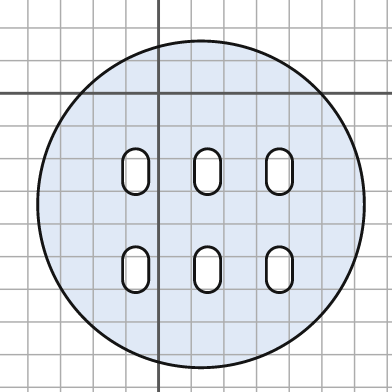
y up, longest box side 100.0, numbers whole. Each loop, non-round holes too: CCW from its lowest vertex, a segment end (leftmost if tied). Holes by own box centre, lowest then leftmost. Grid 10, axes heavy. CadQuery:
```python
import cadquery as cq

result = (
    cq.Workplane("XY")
    .moveTo(13.0, -34.0)
    .circle(50.0)
    .moveTo(-11.0, -57.0)
    .threePointArc((-7.0, -61.0), (-3.0, -57.0))
    .lineTo(-3.0, -51.0)
    .threePointArc((-7.0, -47.0), (-11.0, -51.0))
    .close()
    .moveTo(11.0, -57.0)
    .threePointArc((15.0, -61.0), (19.0, -57.0))
    .lineTo(19.0, -51.0)
    .threePointArc((15.0, -47.0), (11.0, -51.0))
    .close()
    .moveTo(33.0, -57.0)
    .threePointArc((37.0, -61.0), (41.0, -57.0))
    .lineTo(41.0, -51.0)
    .threePointArc((37.0, -47.0), (33.0, -51.0))
    .close()
    .moveTo(-11.0, -27.0)
    .threePointArc((-7.0, -31.0), (-3.0, -27.0))
    .lineTo(-3.0, -21.0)
    .threePointArc((-7.0, -17.0), (-11.0, -21.0))
    .close()
    .moveTo(11.0, -27.0)
    .threePointArc((15.0, -31.0), (19.0, -27.0))
    .lineTo(19.0, -21.0)
    .threePointArc((15.0, -17.0), (11.0, -21.0))
    .close()
    .moveTo(33.0, -27.0)
    .threePointArc((37.0, -31.0), (41.0, -27.0))
    .lineTo(41.0, -21.0)
    .threePointArc((37.0, -17.0), (33.0, -21.0))
    .close()
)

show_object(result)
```